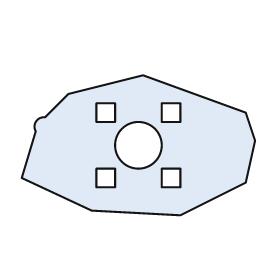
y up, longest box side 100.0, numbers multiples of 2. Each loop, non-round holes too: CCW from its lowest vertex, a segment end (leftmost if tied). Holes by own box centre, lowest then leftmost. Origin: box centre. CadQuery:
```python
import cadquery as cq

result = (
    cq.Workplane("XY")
    .moveTo(18.0, -30.0)
    .lineTo(46.0, -16.0)
    .lineTo(50.0, 2.0)
    .lineTo(46.0, 14.0)
    .lineTo(2.0, 30.0)
    .lineTo(-30.0, 22.0)
    .lineTo(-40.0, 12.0)
    .threePointArc((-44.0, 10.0), (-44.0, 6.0))
    .lineTo(-50.0, -14.0)
    .lineTo(-20.0, -28.0)
    .close()
    .moveTo(-18.0, -18.0)
    .lineTo(-10.0, -18.0)
    .lineTo(-10.0, -10.0)
    .lineTo(-18.0, -10.0)
    .close()
    .moveTo(10.0, -18.0)
    .lineTo(18.0, -18.0)
    .lineTo(18.0, -10.0)
    .lineTo(10.0, -10.0)
    .close()
    .moveTo(0.0, 0.0)
    .circle(10.0)
    .moveTo(-18.0, 10.0)
    .lineTo(-10.0, 10.0)
    .lineTo(-10.0, 18.0)
    .lineTo(-18.0, 18.0)
    .close()
    .moveTo(10.0, 10.0)
    .lineTo(18.0, 10.0)
    .lineTo(18.0, 18.0)
    .lineTo(10.0, 18.0)
    .close()
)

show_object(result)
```